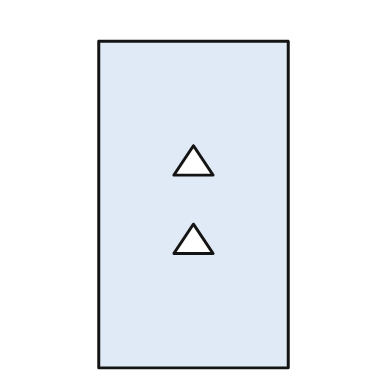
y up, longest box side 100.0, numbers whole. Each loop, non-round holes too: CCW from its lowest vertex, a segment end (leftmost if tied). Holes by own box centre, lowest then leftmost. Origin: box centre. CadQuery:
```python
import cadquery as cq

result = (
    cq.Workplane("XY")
    .moveTo(-29.0, -50.0)
    .lineTo(29.0, -50.0)
    .lineTo(29.0, 50.0)
    .lineTo(-29.0, 50.0)
    .close()
    .moveTo(-6.0, -15.0)
    .lineTo(6.0, -15.0)
    .lineTo(0.0, -6.0)
    .close()
    .moveTo(-6.0, 9.0)
    .lineTo(6.0, 9.0)
    .lineTo(0.0, 18.0)
    .close()
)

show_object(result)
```